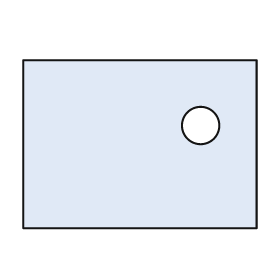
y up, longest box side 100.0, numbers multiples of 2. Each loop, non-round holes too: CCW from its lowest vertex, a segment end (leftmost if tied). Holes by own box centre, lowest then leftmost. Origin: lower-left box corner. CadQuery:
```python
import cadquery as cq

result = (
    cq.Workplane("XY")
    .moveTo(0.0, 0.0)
    .lineTo(100.0, 0.0)
    .lineTo(100.0, 72.0)
    .lineTo(0.0, 72.0)
    .close()
    .moveTo(76.0, 44.0)
    .circle(8.0)
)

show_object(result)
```